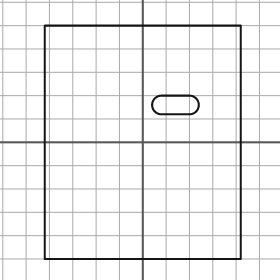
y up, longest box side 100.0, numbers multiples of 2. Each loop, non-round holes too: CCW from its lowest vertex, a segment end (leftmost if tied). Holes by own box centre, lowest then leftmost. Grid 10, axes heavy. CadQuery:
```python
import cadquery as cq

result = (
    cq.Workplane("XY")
    .moveTo(-42.0, -50.0)
    .lineTo(42.0, -50.0)
    .lineTo(42.0, 50.0)
    .lineTo(-42.0, 50.0)
    .close()
    .moveTo(8.0, 12.0)
    .lineTo(20.0, 12.0)
    .threePointArc((24.0, 16.0), (20.0, 20.0))
    .lineTo(8.0, 20.0)
    .threePointArc((4.0, 16.0), (8.0, 12.0))
    .close()
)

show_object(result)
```